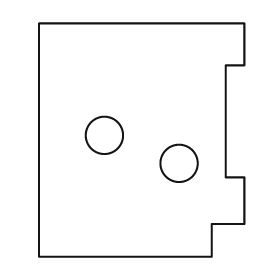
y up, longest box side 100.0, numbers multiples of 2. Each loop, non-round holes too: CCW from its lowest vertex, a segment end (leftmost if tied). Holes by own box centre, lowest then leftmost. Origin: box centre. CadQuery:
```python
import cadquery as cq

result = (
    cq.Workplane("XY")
    .moveTo(-44.0, -50.0)
    .lineTo(30.0, -50.0)
    .lineTo(30.0, -36.0)
    .lineTo(44.0, -36.0)
    .lineTo(44.0, -16.0)
    .lineTo(36.0, -16.0)
    .lineTo(36.0, 32.0)
    .lineTo(44.0, 32.0)
    .lineTo(44.0, 50.0)
    .lineTo(-44.0, 50.0)
    .close()
    .moveTo(16.0, -10.0)
    .circle(8.0)
    .moveTo(-16.0, 2.0)
    .circle(8.0)
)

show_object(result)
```